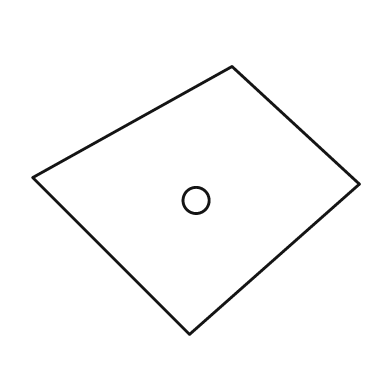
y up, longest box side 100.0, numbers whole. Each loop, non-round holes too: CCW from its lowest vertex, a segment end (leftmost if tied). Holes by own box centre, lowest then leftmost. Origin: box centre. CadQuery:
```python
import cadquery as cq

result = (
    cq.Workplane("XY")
    .moveTo(-2.0, -41.0)
    .lineTo(50.0, 5.0)
    .lineTo(11.0, 41.0)
    .lineTo(-50.0, 7.0)
    .close()
    .moveTo(0.0, 0.0)
    .circle(4.0)
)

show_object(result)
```